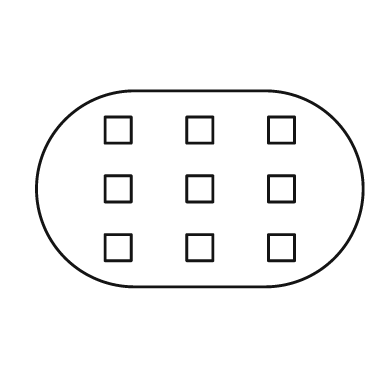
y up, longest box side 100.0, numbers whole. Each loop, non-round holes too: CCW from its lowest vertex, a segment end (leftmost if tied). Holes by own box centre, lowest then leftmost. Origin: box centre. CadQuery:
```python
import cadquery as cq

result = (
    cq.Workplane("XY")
    .moveTo(-20.0, -30.0)
    .lineTo(20.0, -30.0)
    .threePointArc((50.0, 0.0), (20.0, 30.0))
    .lineTo(-20.0, 30.0)
    .threePointArc((-50.0, 0.0), (-20.0, -30.0))
    .close()
    .moveTo(-29.0, -22.0)
    .lineTo(-21.0, -22.0)
    .lineTo(-21.0, -14.0)
    .lineTo(-29.0, -14.0)
    .close()
    .moveTo(-4.0, -22.0)
    .lineTo(4.0, -22.0)
    .lineTo(4.0, -14.0)
    .lineTo(-4.0, -14.0)
    .close()
    .moveTo(21.0, -22.0)
    .lineTo(29.0, -22.0)
    .lineTo(29.0, -14.0)
    .lineTo(21.0, -14.0)
    .close()
    .moveTo(-29.0, -4.0)
    .lineTo(-21.0, -4.0)
    .lineTo(-21.0, 4.0)
    .lineTo(-29.0, 4.0)
    .close()
    .moveTo(-4.0, -4.0)
    .lineTo(4.0, -4.0)
    .lineTo(4.0, 4.0)
    .lineTo(-4.0, 4.0)
    .close()
    .moveTo(21.0, -4.0)
    .lineTo(29.0, -4.0)
    .lineTo(29.0, 4.0)
    .lineTo(21.0, 4.0)
    .close()
    .moveTo(-29.0, 14.0)
    .lineTo(-21.0, 14.0)
    .lineTo(-21.0, 22.0)
    .lineTo(-29.0, 22.0)
    .close()
    .moveTo(-4.0, 14.0)
    .lineTo(4.0, 14.0)
    .lineTo(4.0, 22.0)
    .lineTo(-4.0, 22.0)
    .close()
    .moveTo(21.0, 14.0)
    .lineTo(29.0, 14.0)
    .lineTo(29.0, 22.0)
    .lineTo(21.0, 22.0)
    .close()
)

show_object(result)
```